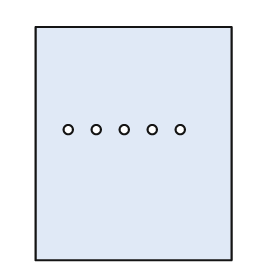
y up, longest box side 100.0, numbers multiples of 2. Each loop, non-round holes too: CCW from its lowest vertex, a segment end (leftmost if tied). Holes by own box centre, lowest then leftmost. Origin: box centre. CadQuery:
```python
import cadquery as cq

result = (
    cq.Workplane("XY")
    .moveTo(-42.0, -50.0)
    .lineTo(42.0, -50.0)
    .lineTo(42.0, 50.0)
    .lineTo(-42.0, 50.0)
    .close()
    .moveTo(-28.0, 6.0)
    .circle(2.0)
    .moveTo(-16.0, 6.0)
    .circle(2.0)
    .moveTo(-4.0, 6.0)
    .circle(2.0)
    .moveTo(8.0, 6.0)
    .circle(2.0)
    .moveTo(20.0, 6.0)
    .circle(2.0)
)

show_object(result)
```